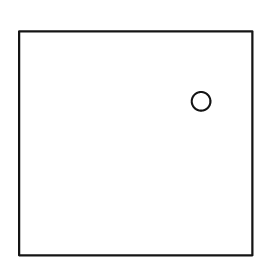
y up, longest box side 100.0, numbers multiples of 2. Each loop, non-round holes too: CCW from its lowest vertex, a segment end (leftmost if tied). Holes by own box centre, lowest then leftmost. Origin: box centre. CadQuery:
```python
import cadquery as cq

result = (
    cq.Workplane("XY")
    .moveTo(-50.0, -48.0)
    .lineTo(50.0, -48.0)
    .lineTo(50.0, 48.0)
    .lineTo(-50.0, 48.0)
    .close()
    .moveTo(28.0, 18.0)
    .circle(4.0)
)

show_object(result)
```